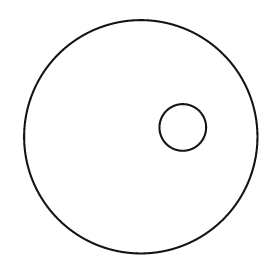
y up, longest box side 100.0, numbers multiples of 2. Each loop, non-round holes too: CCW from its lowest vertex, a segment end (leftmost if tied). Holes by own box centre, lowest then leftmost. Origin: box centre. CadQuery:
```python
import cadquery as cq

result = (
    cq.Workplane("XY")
    .moveTo(0.0, 0.0)
    .circle(50.0)
    .moveTo(18.0, 4.0)
    .circle(10.0)
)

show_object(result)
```